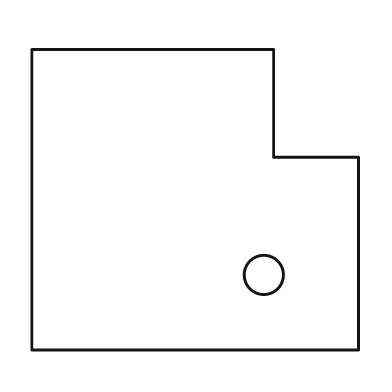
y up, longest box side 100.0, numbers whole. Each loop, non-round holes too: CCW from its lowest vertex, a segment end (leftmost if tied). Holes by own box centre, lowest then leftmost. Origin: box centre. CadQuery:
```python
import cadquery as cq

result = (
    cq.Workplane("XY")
    .moveTo(-50.0, -46.0)
    .lineTo(50.0, -46.0)
    .lineTo(50.0, 13.0)
    .lineTo(24.0, 13.0)
    .lineTo(24.0, 46.0)
    .lineTo(-50.0, 46.0)
    .close()
    .moveTo(21.0, -23.0)
    .circle(6.0)
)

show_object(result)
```